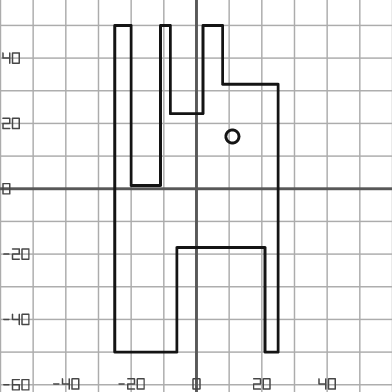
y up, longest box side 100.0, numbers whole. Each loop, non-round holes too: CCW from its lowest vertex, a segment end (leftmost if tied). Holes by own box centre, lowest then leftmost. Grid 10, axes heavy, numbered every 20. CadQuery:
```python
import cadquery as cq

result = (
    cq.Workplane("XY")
    .moveTo(-25.0, -50.0)
    .lineTo(-6.0, -50.0)
    .lineTo(-6.0, -18.0)
    .lineTo(21.0, -18.0)
    .lineTo(21.0, -50.0)
    .lineTo(25.0, -50.0)
    .lineTo(25.0, 32.0)
    .lineTo(8.0, 32.0)
    .lineTo(8.0, 50.0)
    .lineTo(2.0, 50.0)
    .lineTo(2.0, 23.0)
    .lineTo(-8.0, 23.0)
    .lineTo(-8.0, 50.0)
    .lineTo(-11.0, 50.0)
    .lineTo(-11.0, 1.0)
    .lineTo(-20.0, 1.0)
    .lineTo(-20.0, 50.0)
    .lineTo(-25.0, 50.0)
    .close()
    .moveTo(11.0, 16.0)
    .circle(2.0)
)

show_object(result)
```